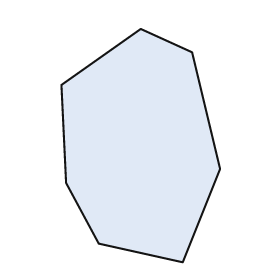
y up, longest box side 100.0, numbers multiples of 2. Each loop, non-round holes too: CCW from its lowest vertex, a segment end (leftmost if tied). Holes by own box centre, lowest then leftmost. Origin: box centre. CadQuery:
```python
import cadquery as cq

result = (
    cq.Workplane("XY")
    .moveTo(18.0, -50.0)
    .lineTo(34.0, -10.0)
    .lineTo(22.0, 40.0)
    .lineTo(0.0, 50.0)
    .lineTo(-34.0, 26.0)
    .lineTo(-32.0, -16.0)
    .lineTo(-18.0, -42.0)
    .close()
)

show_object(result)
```